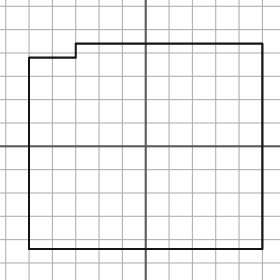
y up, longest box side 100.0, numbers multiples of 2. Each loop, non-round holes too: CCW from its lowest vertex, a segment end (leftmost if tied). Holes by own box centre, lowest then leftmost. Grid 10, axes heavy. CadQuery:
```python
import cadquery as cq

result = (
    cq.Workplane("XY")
    .moveTo(-50.0, -44.0)
    .lineTo(50.0, -44.0)
    .lineTo(50.0, 44.0)
    .lineTo(-30.0, 44.0)
    .lineTo(-30.0, 38.0)
    .lineTo(-50.0, 38.0)
    .close()
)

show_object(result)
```